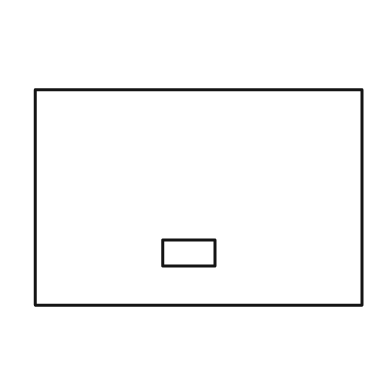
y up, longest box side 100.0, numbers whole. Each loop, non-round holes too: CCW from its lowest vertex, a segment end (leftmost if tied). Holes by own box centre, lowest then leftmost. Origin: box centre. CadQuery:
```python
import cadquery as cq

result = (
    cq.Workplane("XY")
    .moveTo(-50.0, -33.0)
    .lineTo(50.0, -33.0)
    .lineTo(50.0, 33.0)
    .lineTo(-50.0, 33.0)
    .close()
    .moveTo(-11.0, -21.0)
    .lineTo(5.0, -21.0)
    .lineTo(5.0, -13.0)
    .lineTo(-11.0, -13.0)
    .close()
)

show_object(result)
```